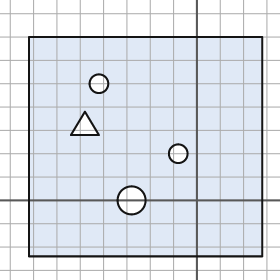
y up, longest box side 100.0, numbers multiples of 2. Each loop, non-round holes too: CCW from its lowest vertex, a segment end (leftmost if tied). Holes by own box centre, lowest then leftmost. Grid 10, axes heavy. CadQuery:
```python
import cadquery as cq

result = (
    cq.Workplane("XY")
    .moveTo(-72.0, -24.0)
    .lineTo(28.0, -24.0)
    .lineTo(28.0, 70.0)
    .lineTo(-72.0, 70.0)
    .close()
    .moveTo(-28.0, 0.0)
    .circle(6.0)
    .moveTo(-8.0, 20.0)
    .circle(4.0)
    .moveTo(-54.0, 28.0)
    .lineTo(-42.0, 28.0)
    .lineTo(-48.0, 38.0)
    .close()
    .moveTo(-42.0, 50.0)
    .circle(4.0)
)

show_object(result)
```